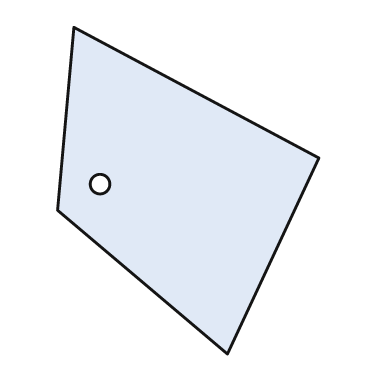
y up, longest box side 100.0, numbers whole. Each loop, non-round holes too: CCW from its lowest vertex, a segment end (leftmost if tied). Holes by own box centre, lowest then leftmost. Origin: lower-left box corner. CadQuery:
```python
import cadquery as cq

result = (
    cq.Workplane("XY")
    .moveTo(52.0, 0.0)
    .lineTo(80.0, 60.0)
    .lineTo(5.0, 100.0)
    .lineTo(0.0, 44.0)
    .close()
    .moveTo(13.0, 52.0)
    .circle(3.0)
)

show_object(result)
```